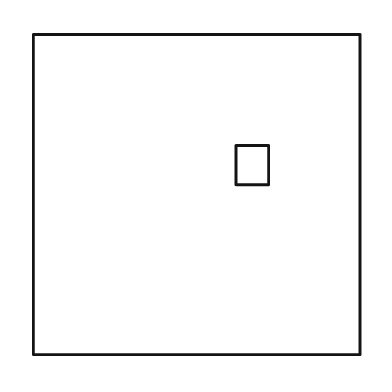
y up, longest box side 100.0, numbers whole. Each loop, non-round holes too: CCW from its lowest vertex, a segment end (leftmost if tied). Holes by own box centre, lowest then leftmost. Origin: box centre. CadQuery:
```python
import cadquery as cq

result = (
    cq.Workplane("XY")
    .moveTo(-50.0, -49.0)
    .lineTo(50.0, -49.0)
    .lineTo(50.0, 49.0)
    .lineTo(-50.0, 49.0)
    .close()
    .moveTo(12.0, 3.0)
    .lineTo(22.0, 3.0)
    .lineTo(22.0, 15.0)
    .lineTo(12.0, 15.0)
    .close()
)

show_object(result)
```